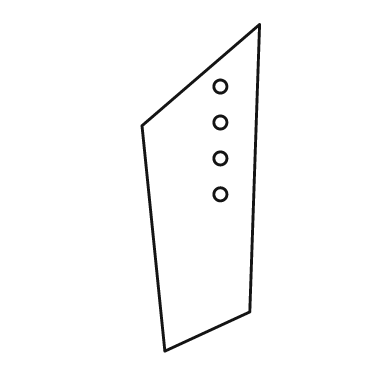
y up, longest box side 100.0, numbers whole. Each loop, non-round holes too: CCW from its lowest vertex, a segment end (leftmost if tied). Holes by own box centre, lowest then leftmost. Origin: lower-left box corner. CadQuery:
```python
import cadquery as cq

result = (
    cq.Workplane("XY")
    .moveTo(7.0, 0.0)
    .lineTo(33.0, 12.0)
    .lineTo(36.0, 100.0)
    .lineTo(0.0, 69.0)
    .close()
    .moveTo(24.0, 48.0)
    .circle(2.0)
    .moveTo(24.0, 59.0)
    .circle(2.0)
    .moveTo(24.0, 70.0)
    .circle(2.0)
    .moveTo(24.0, 81.0)
    .circle(2.0)
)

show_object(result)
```